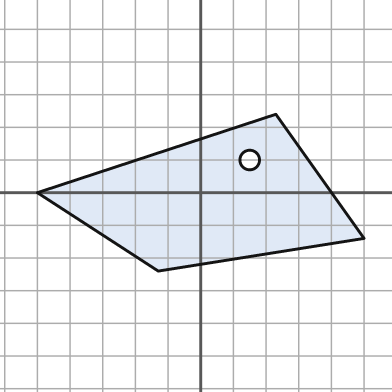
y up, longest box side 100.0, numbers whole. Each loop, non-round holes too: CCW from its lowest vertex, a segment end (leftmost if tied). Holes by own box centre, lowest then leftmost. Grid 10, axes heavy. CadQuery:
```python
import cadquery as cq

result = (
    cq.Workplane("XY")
    .moveTo(-13.0, -24.0)
    .lineTo(50.0, -14.0)
    .lineTo(23.0, 24.0)
    .lineTo(-50.0, 0.0)
    .close()
    .moveTo(15.0, 10.0)
    .circle(3.0)
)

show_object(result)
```